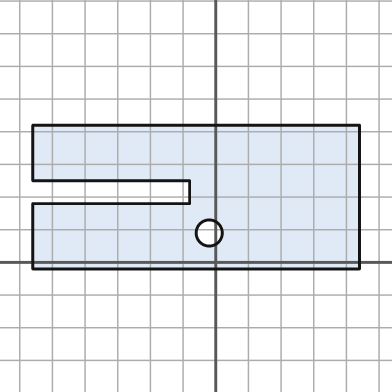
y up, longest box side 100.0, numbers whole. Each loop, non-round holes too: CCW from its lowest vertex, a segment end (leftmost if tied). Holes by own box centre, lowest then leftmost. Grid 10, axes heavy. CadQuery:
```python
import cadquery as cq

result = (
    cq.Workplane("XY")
    .moveTo(-56.0, -2.0)
    .lineTo(44.0, -2.0)
    .lineTo(44.0, 42.0)
    .lineTo(-56.0, 42.0)
    .lineTo(-56.0, 25.0)
    .lineTo(-8.0, 25.0)
    .lineTo(-8.0, 18.0)
    .lineTo(-56.0, 18.0)
    .close()
    .moveTo(-2.0, 9.0)
    .circle(4.0)
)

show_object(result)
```